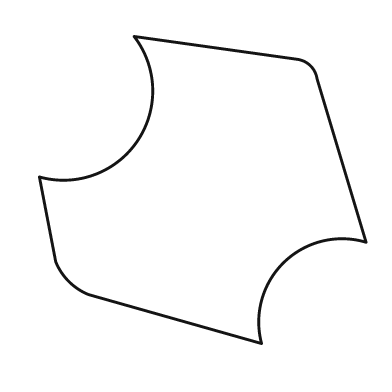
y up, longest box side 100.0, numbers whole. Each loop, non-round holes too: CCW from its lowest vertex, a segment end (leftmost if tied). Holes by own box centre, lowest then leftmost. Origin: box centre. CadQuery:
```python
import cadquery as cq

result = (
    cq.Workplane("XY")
    .moveTo(18.0, -47.0)
    .threePointArc((25.0, -22.0), (50.0, -16.0))
    .lineTo(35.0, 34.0)
    .threePointArc((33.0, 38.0), (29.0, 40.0))
    .lineTo(-21.0, 47.0)
    .threePointArc((-20.0, 15.0), (-50.0, 4.0))
    .lineTo(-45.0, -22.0)
    .threePointArc((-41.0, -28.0), (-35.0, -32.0))
    .close()
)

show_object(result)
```